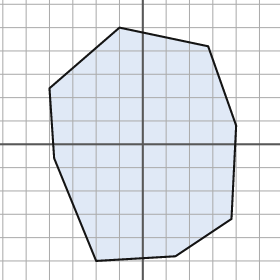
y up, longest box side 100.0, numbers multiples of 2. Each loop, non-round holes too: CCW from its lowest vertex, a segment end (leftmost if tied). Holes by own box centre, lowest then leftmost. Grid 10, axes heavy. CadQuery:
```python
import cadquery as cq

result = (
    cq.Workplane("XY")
    .moveTo(-20.0, -50.0)
    .lineTo(14.0, -48.0)
    .lineTo(38.0, -32.0)
    .lineTo(40.0, 8.0)
    .lineTo(28.0, 42.0)
    .lineTo(-10.0, 50.0)
    .lineTo(-40.0, 24.0)
    .lineTo(-38.0, -6.0)
    .close()
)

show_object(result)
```